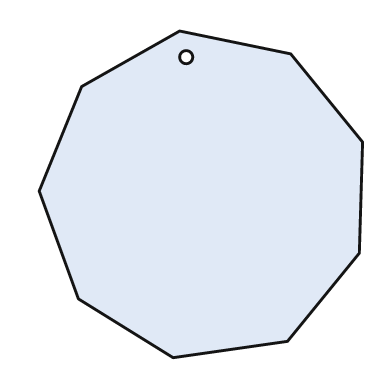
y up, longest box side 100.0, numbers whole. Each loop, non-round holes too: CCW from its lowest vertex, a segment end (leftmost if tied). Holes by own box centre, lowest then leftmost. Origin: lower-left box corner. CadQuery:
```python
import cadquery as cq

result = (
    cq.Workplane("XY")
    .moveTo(41.0, 0.0)
    .lineTo(76.0, 5.0)
    .lineTo(98.0, 32.0)
    .lineTo(99.0, 66.0)
    .lineTo(77.0, 93.0)
    .lineTo(43.0, 100.0)
    .lineTo(13.0, 83.0)
    .lineTo(0.0, 51.0)
    .lineTo(12.0, 18.0)
    .close()
    .moveTo(45.0, 92.0)
    .circle(2.0)
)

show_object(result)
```